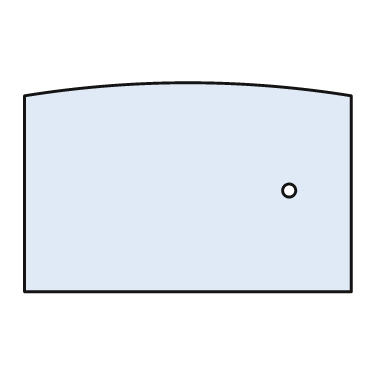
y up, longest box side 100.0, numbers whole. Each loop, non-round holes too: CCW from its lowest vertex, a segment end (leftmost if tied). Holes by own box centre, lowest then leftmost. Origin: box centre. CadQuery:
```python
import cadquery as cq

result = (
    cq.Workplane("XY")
    .moveTo(-50.0, -32.0)
    .lineTo(50.0, -32.0)
    .lineTo(50.0, 28.0)
    .threePointArc((0.0, 32.0), (-50.0, 28.0))
    .close()
    .moveTo(31.0, -1.0)
    .circle(2.0)
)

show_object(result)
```